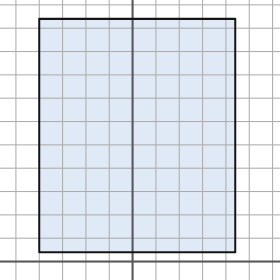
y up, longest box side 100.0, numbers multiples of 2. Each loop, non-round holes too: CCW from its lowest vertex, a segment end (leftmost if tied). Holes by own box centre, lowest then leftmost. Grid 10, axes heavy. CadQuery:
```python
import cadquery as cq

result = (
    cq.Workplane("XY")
    .moveTo(-40.0, 4.0)
    .lineTo(44.0, 4.0)
    .lineTo(44.0, 104.0)
    .lineTo(-40.0, 104.0)
    .close()
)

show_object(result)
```